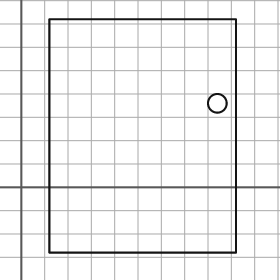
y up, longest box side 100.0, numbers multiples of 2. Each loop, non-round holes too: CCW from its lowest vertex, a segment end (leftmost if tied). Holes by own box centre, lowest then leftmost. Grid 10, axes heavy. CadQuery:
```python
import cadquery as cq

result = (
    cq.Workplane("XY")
    .moveTo(12.0, -28.0)
    .lineTo(92.0, -28.0)
    .lineTo(92.0, 72.0)
    .lineTo(12.0, 72.0)
    .close()
    .moveTo(84.0, 36.0)
    .circle(4.0)
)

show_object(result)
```